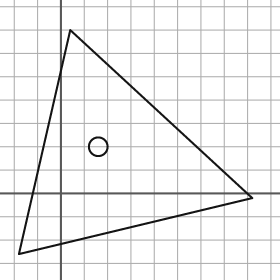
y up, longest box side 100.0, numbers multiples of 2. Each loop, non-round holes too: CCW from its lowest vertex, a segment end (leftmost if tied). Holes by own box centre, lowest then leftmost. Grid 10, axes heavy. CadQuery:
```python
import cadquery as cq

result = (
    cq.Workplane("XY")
    .moveTo(-18.0, -26.0)
    .lineTo(82.0, -2.0)
    .lineTo(4.0, 70.0)
    .close()
    .moveTo(16.0, 20.0)
    .circle(4.0)
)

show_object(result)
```